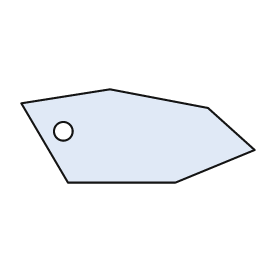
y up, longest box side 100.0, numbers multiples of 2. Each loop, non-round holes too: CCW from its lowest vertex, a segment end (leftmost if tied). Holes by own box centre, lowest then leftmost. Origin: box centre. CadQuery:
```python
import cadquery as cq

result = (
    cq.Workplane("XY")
    .moveTo(-30.0, -20.0)
    .lineTo(16.0, -20.0)
    .lineTo(50.0, -6.0)
    .lineTo(30.0, 12.0)
    .lineTo(-12.0, 20.0)
    .lineTo(-50.0, 14.0)
    .close()
    .moveTo(-32.0, 2.0)
    .circle(4.0)
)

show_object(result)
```